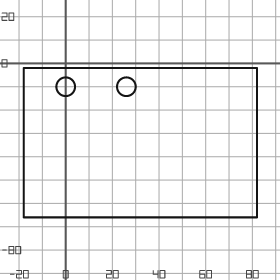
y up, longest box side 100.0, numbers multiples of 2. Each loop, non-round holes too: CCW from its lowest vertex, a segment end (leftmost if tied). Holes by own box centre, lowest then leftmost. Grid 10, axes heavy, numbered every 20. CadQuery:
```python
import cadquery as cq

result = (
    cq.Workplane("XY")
    .moveTo(-18.0, -66.0)
    .lineTo(82.0, -66.0)
    .lineTo(82.0, -2.0)
    .lineTo(-18.0, -2.0)
    .close()
    .moveTo(0.0, -10.0)
    .circle(4.0)
    .moveTo(26.0, -10.0)
    .circle(4.0)
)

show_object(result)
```